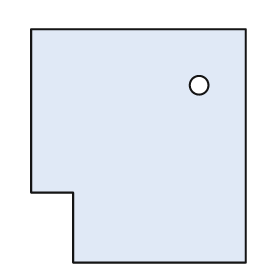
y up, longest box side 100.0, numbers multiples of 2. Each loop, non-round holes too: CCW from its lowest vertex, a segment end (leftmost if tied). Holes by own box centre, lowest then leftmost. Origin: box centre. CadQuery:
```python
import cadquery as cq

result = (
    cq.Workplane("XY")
    .moveTo(-28.0, -50.0)
    .lineTo(46.0, -50.0)
    .lineTo(46.0, 50.0)
    .lineTo(-46.0, 50.0)
    .lineTo(-46.0, -20.0)
    .lineTo(-28.0, -20.0)
    .close()
    .moveTo(26.0, 26.0)
    .circle(4.0)
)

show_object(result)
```